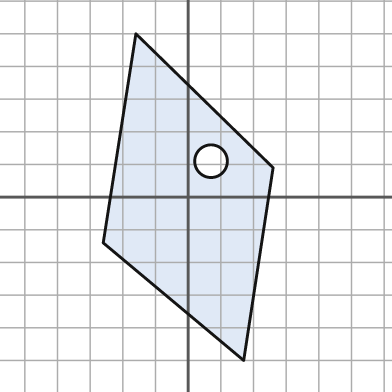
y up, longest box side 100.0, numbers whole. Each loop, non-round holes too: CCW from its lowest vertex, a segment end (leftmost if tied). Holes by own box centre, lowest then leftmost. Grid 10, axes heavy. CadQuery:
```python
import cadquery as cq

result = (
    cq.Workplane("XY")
    .moveTo(17.0, -50.0)
    .lineTo(26.0, 9.0)
    .lineTo(-16.0, 50.0)
    .lineTo(-26.0, -14.0)
    .close()
    .moveTo(7.0, 11.0)
    .circle(5.0)
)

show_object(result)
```